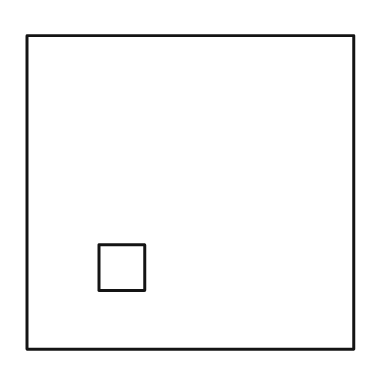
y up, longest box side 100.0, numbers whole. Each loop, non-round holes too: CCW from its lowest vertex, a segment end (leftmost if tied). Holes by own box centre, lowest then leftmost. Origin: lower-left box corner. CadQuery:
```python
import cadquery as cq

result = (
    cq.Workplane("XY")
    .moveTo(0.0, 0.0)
    .lineTo(100.0, 0.0)
    .lineTo(100.0, 96.0)
    .lineTo(0.0, 96.0)
    .close()
    .moveTo(22.0, 18.0)
    .lineTo(36.0, 18.0)
    .lineTo(36.0, 32.0)
    .lineTo(22.0, 32.0)
    .close()
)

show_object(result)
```